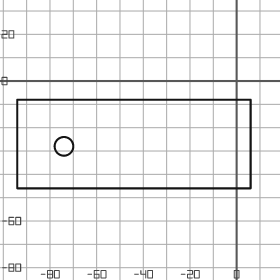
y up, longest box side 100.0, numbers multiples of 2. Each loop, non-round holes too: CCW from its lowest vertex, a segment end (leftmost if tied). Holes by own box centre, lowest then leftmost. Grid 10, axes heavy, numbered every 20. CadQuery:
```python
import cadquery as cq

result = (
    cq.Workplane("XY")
    .moveTo(-94.0, -46.0)
    .lineTo(6.0, -46.0)
    .lineTo(6.0, -8.0)
    .lineTo(-94.0, -8.0)
    .close()
    .moveTo(-74.0, -28.0)
    .circle(4.0)
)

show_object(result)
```